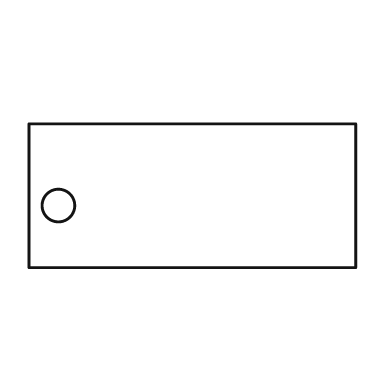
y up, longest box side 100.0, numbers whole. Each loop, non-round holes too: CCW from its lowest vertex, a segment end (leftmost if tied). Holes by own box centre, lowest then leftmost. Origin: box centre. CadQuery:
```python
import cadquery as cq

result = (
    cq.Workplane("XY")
    .moveTo(-50.0, -22.0)
    .lineTo(50.0, -22.0)
    .lineTo(50.0, 22.0)
    .lineTo(-50.0, 22.0)
    .close()
    .moveTo(-41.0, -3.0)
    .circle(5.0)
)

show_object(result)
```